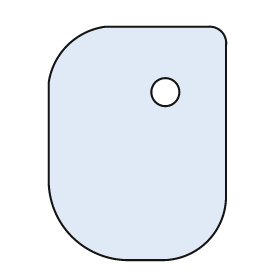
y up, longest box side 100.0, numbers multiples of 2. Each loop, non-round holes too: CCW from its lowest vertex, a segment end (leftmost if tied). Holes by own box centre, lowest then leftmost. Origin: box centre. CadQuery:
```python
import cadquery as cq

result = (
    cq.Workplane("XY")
    .moveTo(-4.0, -50.0)
    .lineTo(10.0, -50.0)
    .threePointArc((30.0, -42.0), (38.0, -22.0))
    .lineTo(38.0, 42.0)
    .threePointArc((36.0, 48.0), (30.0, 50.0))
    .lineTo(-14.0, 50.0)
    .threePointArc((-30.0, 42.0), (-38.0, 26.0))
    .lineTo(-38.0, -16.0)
    .threePointArc((-28.0, -40.0), (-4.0, -50.0))
    .close()
    .moveTo(12.0, 22.0)
    .circle(6.0)
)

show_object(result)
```